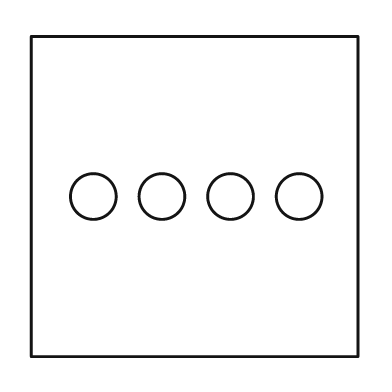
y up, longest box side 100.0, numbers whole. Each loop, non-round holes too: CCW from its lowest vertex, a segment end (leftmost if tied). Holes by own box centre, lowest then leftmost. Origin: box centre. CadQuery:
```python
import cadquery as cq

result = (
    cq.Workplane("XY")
    .moveTo(-50.0, -49.0)
    .lineTo(50.0, -49.0)
    .lineTo(50.0, 49.0)
    .lineTo(-50.0, 49.0)
    .close()
    .moveTo(-31.0, 0.0)
    .circle(7.0)
    .moveTo(-10.0, 0.0)
    .circle(7.0)
    .moveTo(11.0, 0.0)
    .circle(7.0)
    .moveTo(32.0, 0.0)
    .circle(7.0)
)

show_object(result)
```